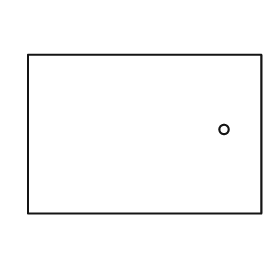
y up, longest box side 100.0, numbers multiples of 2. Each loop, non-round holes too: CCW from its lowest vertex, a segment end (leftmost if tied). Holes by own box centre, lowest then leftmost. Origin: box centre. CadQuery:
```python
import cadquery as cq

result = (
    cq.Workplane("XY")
    .moveTo(-50.0, -34.0)
    .lineTo(50.0, -34.0)
    .lineTo(50.0, 34.0)
    .lineTo(-50.0, 34.0)
    .close()
    .moveTo(34.0, 2.0)
    .circle(2.0)
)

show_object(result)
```